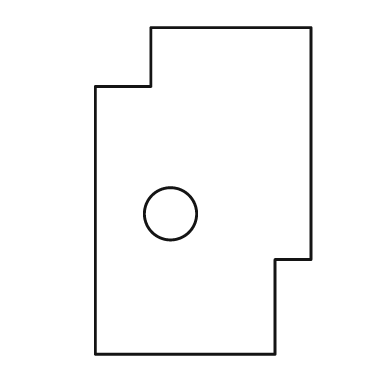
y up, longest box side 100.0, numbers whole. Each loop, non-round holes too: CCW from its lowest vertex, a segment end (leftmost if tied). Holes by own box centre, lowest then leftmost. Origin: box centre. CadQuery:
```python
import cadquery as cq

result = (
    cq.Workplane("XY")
    .moveTo(-33.0, -50.0)
    .lineTo(22.0, -50.0)
    .lineTo(22.0, -21.0)
    .lineTo(33.0, -21.0)
    .lineTo(33.0, 50.0)
    .lineTo(-16.0, 50.0)
    .lineTo(-16.0, 32.0)
    .lineTo(-33.0, 32.0)
    .close()
    .moveTo(-10.0, -7.0)
    .circle(8.0)
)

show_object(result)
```